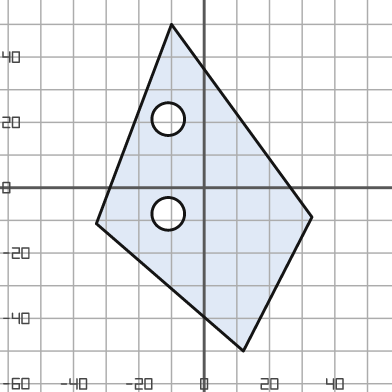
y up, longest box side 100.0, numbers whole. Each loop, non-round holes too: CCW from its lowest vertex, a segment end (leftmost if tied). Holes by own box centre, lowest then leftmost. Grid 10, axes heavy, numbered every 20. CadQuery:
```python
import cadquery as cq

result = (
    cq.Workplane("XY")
    .moveTo(12.0, -50.0)
    .lineTo(33.0, -9.0)
    .lineTo(-10.0, 50.0)
    .lineTo(-33.0, -11.0)
    .close()
    .moveTo(-11.0, -8.0)
    .circle(5.0)
    .moveTo(-11.0, 21.0)
    .circle(5.0)
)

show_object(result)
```